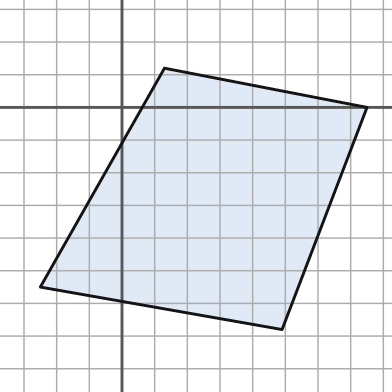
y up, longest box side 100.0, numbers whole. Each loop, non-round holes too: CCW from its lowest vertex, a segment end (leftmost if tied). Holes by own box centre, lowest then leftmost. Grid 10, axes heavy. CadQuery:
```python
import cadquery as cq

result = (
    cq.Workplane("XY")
    .moveTo(49.0, -68.0)
    .lineTo(75.0, 0.0)
    .lineTo(13.0, 12.0)
    .lineTo(-25.0, -55.0)
    .close()
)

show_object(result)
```